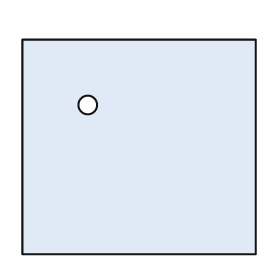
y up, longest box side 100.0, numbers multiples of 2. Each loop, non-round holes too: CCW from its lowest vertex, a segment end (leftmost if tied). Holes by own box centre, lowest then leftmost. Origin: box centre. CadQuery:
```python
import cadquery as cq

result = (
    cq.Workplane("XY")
    .moveTo(-50.0, -46.0)
    .lineTo(50.0, -46.0)
    .lineTo(50.0, 46.0)
    .lineTo(-50.0, 46.0)
    .close()
    .moveTo(-22.0, 18.0)
    .circle(4.0)
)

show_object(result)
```